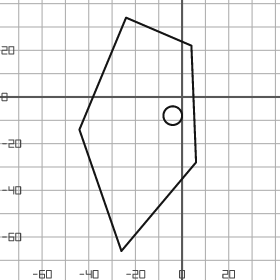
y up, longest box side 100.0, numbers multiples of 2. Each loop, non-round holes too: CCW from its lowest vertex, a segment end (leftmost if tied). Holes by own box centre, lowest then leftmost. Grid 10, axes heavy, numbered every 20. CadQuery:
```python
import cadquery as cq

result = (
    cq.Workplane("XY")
    .moveTo(-26.0, -66.0)
    .lineTo(6.0, -28.0)
    .lineTo(4.0, 22.0)
    .lineTo(-24.0, 34.0)
    .lineTo(-44.0, -14.0)
    .close()
    .moveTo(-4.0, -8.0)
    .circle(4.0)
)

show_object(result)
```